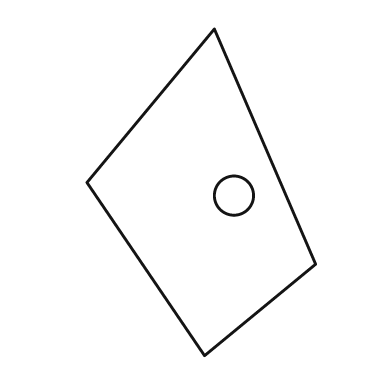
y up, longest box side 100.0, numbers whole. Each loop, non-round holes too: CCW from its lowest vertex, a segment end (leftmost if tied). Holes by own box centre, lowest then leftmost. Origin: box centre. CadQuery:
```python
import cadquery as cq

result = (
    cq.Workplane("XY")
    .moveTo(1.0, -50.0)
    .lineTo(35.0, -22.0)
    .lineTo(4.0, 50.0)
    .lineTo(-35.0, 3.0)
    .close()
    .moveTo(10.0, -1.0)
    .circle(6.0)
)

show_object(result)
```